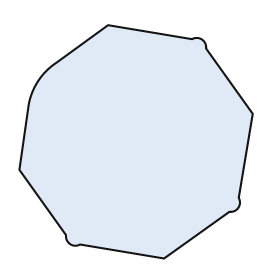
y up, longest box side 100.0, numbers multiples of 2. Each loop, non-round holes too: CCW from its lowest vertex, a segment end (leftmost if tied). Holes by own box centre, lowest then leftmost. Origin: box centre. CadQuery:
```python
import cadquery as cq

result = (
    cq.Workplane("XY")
    .moveTo(12.0, -50.0)
    .lineTo(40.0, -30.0)
    .threePointArc((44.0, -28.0), (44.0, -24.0))
    .lineTo(50.0, 12.0)
    .lineTo(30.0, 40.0)
    .threePointArc((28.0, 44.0), (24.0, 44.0))
    .lineTo(-12.0, 50.0)
    .lineTo(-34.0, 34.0)
    .threePointArc((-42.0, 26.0), (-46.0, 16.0))
    .lineTo(-50.0, -12.0)
    .lineTo(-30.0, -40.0)
    .threePointArc((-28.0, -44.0), (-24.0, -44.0))
    .close()
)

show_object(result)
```